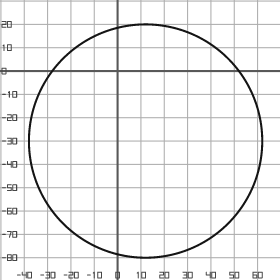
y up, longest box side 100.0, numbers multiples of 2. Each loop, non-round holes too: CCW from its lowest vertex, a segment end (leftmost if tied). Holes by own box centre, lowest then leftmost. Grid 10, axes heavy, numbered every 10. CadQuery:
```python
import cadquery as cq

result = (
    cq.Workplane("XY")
    .moveTo(12.0, -30.0)
    .circle(50.0)
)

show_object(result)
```